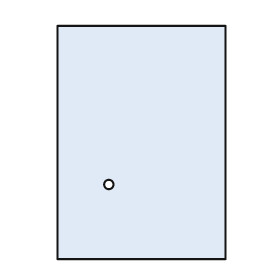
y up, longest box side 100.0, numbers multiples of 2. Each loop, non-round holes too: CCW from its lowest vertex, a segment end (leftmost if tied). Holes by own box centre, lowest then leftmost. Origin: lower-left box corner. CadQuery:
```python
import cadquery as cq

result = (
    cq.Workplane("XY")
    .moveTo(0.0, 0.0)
    .lineTo(72.0, 0.0)
    .lineTo(72.0, 100.0)
    .lineTo(0.0, 100.0)
    .close()
    .moveTo(22.0, 32.0)
    .circle(2.0)
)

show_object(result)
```